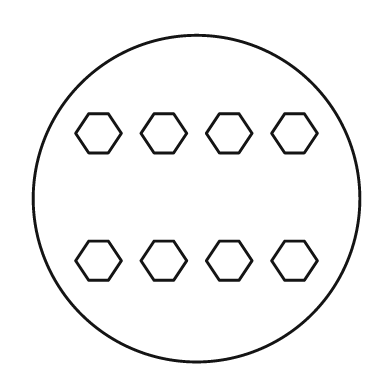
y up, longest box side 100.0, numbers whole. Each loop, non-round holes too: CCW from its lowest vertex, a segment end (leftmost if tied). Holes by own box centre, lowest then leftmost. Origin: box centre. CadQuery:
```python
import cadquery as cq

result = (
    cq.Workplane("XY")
    .moveTo(0.0, 0.0)
    .circle(50.0)
    .moveTo(-33.0, -25.0)
    .lineTo(-27.0, -25.0)
    .lineTo(-23.0, -19.0)
    .lineTo(-27.0, -13.0)
    .lineTo(-33.0, -13.0)
    .lineTo(-37.0, -19.0)
    .close()
    .moveTo(-13.0, -25.0)
    .lineTo(-7.0, -25.0)
    .lineTo(-3.0, -19.0)
    .lineTo(-7.0, -13.0)
    .lineTo(-13.0, -13.0)
    .lineTo(-17.0, -19.0)
    .close()
    .moveTo(7.0, -25.0)
    .lineTo(13.0, -25.0)
    .lineTo(17.0, -19.0)
    .lineTo(13.0, -13.0)
    .lineTo(7.0, -13.0)
    .lineTo(3.0, -19.0)
    .close()
    .moveTo(27.0, -25.0)
    .lineTo(33.0, -25.0)
    .lineTo(37.0, -19.0)
    .lineTo(33.0, -13.0)
    .lineTo(27.0, -13.0)
    .lineTo(23.0, -19.0)
    .close()
    .moveTo(-33.0, 14.0)
    .lineTo(-27.0, 14.0)
    .lineTo(-23.0, 20.0)
    .lineTo(-27.0, 26.0)
    .lineTo(-33.0, 26.0)
    .lineTo(-37.0, 20.0)
    .close()
    .moveTo(-13.0, 14.0)
    .lineTo(-7.0, 14.0)
    .lineTo(-3.0, 20.0)
    .lineTo(-7.0, 26.0)
    .lineTo(-13.0, 26.0)
    .lineTo(-17.0, 20.0)
    .close()
    .moveTo(7.0, 14.0)
    .lineTo(13.0, 14.0)
    .lineTo(17.0, 20.0)
    .lineTo(13.0, 26.0)
    .lineTo(7.0, 26.0)
    .lineTo(3.0, 20.0)
    .close()
    .moveTo(27.0, 14.0)
    .lineTo(33.0, 14.0)
    .lineTo(37.0, 20.0)
    .lineTo(33.0, 26.0)
    .lineTo(27.0, 26.0)
    .lineTo(23.0, 20.0)
    .close()
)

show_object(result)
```